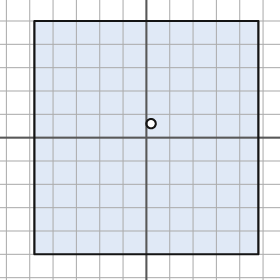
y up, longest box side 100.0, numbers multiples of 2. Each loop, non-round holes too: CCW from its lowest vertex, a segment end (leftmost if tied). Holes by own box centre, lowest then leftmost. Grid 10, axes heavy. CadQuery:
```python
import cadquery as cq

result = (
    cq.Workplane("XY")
    .moveTo(-48.0, -50.0)
    .lineTo(48.0, -50.0)
    .lineTo(48.0, 50.0)
    .lineTo(-48.0, 50.0)
    .close()
    .moveTo(2.0, 6.0)
    .circle(2.0)
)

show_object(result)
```